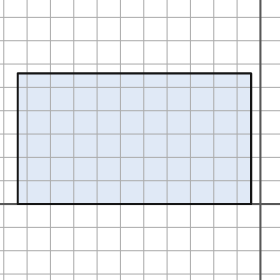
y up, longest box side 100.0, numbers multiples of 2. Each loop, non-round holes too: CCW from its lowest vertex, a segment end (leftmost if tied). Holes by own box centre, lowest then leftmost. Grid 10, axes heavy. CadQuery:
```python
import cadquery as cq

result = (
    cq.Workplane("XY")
    .moveTo(-104.0, 0.0)
    .lineTo(-4.0, 0.0)
    .lineTo(-4.0, 56.0)
    .lineTo(-104.0, 56.0)
    .close()
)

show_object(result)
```